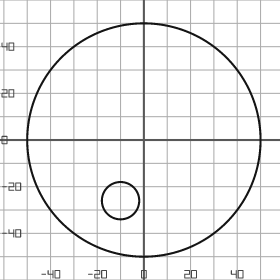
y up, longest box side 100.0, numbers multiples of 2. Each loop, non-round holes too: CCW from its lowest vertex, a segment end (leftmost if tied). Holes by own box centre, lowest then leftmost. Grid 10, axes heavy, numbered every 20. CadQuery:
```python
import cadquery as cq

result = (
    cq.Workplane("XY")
    .moveTo(0.0, 0.0)
    .circle(50.0)
    .moveTo(-10.0, -26.0)
    .circle(8.0)
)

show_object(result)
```